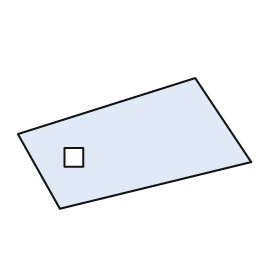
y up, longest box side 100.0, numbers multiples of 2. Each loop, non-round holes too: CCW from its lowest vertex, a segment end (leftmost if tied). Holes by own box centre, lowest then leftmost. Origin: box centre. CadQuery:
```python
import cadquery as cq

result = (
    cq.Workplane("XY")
    .moveTo(-32.0, -28.0)
    .lineTo(50.0, -8.0)
    .lineTo(26.0, 28.0)
    .lineTo(-50.0, 4.0)
    .close()
    .moveTo(-30.0, -10.0)
    .lineTo(-22.0, -10.0)
    .lineTo(-22.0, -2.0)
    .lineTo(-30.0, -2.0)
    .close()
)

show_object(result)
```